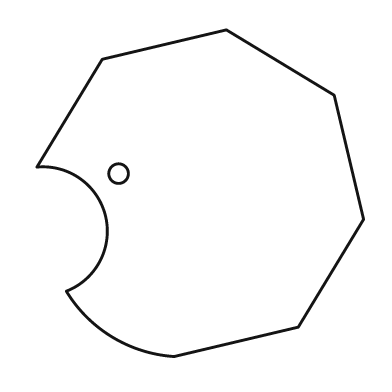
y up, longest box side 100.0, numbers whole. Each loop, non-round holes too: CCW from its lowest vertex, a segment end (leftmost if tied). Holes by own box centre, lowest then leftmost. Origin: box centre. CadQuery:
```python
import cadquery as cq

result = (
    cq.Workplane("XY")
    .moveTo(-8.0, -50.0)
    .lineTo(30.0, -41.0)
    .lineTo(50.0, -8.0)
    .lineTo(41.0, 30.0)
    .lineTo(8.0, 50.0)
    .lineTo(-30.0, 41.0)
    .lineTo(-50.0, 8.0)
    .threePointArc((-29.0, -7.0), (-41.0, -30.0))
    .threePointArc((-27.0, -44.0), (-8.0, -50.0))
    .close()
    .moveTo(-25.0, 6.0)
    .circle(3.0)
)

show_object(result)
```